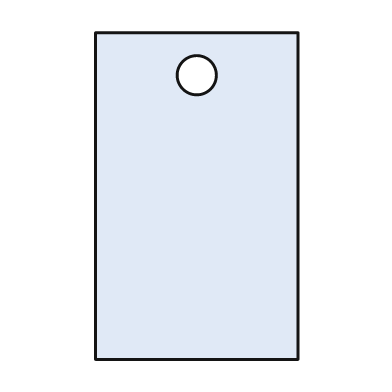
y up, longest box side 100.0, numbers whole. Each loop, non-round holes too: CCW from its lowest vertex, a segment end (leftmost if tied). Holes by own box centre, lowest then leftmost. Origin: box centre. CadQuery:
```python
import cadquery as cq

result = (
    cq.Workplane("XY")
    .moveTo(-31.0, -50.0)
    .lineTo(31.0, -50.0)
    .lineTo(31.0, 50.0)
    .lineTo(-31.0, 50.0)
    .close()
    .moveTo(0.0, 37.0)
    .circle(6.0)
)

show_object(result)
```